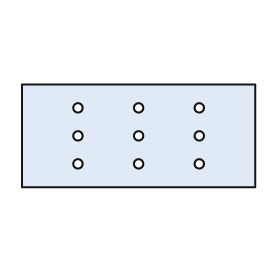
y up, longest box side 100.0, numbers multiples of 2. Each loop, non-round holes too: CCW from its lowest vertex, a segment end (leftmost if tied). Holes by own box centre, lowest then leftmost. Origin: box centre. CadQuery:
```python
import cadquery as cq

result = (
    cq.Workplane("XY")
    .moveTo(-50.0, -22.0)
    .lineTo(50.0, -22.0)
    .lineTo(50.0, 22.0)
    .lineTo(-50.0, 22.0)
    .close()
    .moveTo(-26.0, -12.0)
    .circle(2.0)
    .moveTo(0.0, -12.0)
    .circle(2.0)
    .moveTo(26.0, -12.0)
    .circle(2.0)
    .moveTo(-26.0, 0.0)
    .circle(2.0)
    .moveTo(0.0, 0.0)
    .circle(2.0)
    .moveTo(26.0, 0.0)
    .circle(2.0)
    .moveTo(-26.0, 12.0)
    .circle(2.0)
    .moveTo(0.0, 12.0)
    .circle(2.0)
    .moveTo(26.0, 12.0)
    .circle(2.0)
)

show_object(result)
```